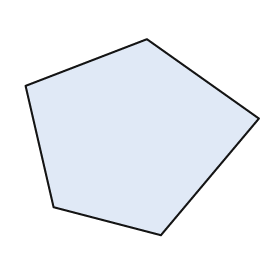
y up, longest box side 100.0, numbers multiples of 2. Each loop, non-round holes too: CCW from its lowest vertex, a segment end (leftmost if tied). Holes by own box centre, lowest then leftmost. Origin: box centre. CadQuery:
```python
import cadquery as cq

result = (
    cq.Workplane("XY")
    .moveTo(8.0, -42.0)
    .lineTo(50.0, 8.0)
    .lineTo(2.0, 42.0)
    .lineTo(-50.0, 22.0)
    .lineTo(-38.0, -30.0)
    .close()
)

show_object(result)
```